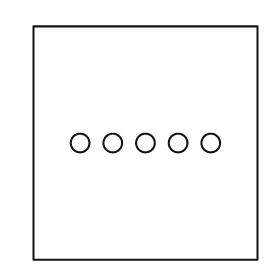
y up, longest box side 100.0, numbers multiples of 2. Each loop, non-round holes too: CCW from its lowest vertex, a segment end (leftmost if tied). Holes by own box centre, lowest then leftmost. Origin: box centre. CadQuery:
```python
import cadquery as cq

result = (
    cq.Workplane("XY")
    .moveTo(-48.0, -50.0)
    .lineTo(48.0, -50.0)
    .lineTo(48.0, 50.0)
    .lineTo(-48.0, 50.0)
    .close()
    .moveTo(-28.0, 0.0)
    .circle(4.0)
    .moveTo(-14.0, 0.0)
    .circle(4.0)
    .moveTo(0.0, 0.0)
    .circle(4.0)
    .moveTo(14.0, 0.0)
    .circle(4.0)
    .moveTo(28.0, 0.0)
    .circle(4.0)
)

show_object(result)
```